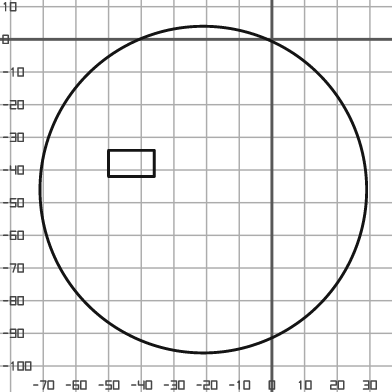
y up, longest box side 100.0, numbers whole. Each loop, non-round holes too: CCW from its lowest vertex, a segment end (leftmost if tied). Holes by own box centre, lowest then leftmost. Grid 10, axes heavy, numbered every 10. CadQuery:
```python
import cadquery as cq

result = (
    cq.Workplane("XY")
    .moveTo(-21.0, -46.0)
    .circle(50.0)
    .moveTo(-50.0, -42.0)
    .lineTo(-36.0, -42.0)
    .lineTo(-36.0, -34.0)
    .lineTo(-50.0, -34.0)
    .close()
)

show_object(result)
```